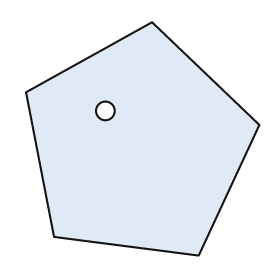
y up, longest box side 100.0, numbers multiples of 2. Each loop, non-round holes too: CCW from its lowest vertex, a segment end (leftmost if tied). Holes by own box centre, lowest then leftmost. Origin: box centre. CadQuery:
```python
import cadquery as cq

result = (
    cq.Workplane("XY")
    .moveTo(24.0, -50.0)
    .lineTo(50.0, 6.0)
    .lineTo(4.0, 50.0)
    .lineTo(-50.0, 20.0)
    .lineTo(-38.0, -42.0)
    .close()
    .moveTo(-16.0, 12.0)
    .circle(4.0)
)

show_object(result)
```